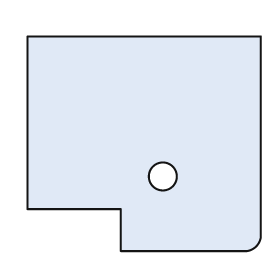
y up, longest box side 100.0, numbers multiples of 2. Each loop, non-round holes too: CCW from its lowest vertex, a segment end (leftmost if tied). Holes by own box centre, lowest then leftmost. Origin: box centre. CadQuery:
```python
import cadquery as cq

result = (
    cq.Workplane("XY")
    .moveTo(-10.0, -46.0)
    .lineTo(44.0, -46.0)
    .threePointArc((48.0, -44.0), (50.0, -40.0))
    .lineTo(50.0, 46.0)
    .lineTo(-50.0, 46.0)
    .lineTo(-50.0, -28.0)
    .lineTo(-10.0, -28.0)
    .close()
    .moveTo(8.0, -14.0)
    .circle(6.0)
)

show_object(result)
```